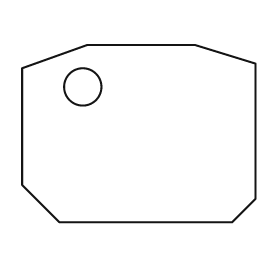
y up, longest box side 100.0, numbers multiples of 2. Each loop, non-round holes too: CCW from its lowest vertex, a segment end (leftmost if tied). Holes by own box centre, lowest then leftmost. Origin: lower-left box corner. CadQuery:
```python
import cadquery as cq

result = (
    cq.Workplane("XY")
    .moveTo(16.0, 0.0)
    .lineTo(90.0, 0.0)
    .lineTo(100.0, 10.0)
    .lineTo(100.0, 68.0)
    .lineTo(74.0, 76.0)
    .lineTo(28.0, 76.0)
    .lineTo(0.0, 66.0)
    .lineTo(0.0, 16.0)
    .close()
    .moveTo(26.0, 58.0)
    .circle(8.0)
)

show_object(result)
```